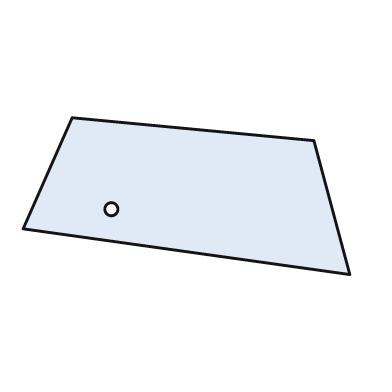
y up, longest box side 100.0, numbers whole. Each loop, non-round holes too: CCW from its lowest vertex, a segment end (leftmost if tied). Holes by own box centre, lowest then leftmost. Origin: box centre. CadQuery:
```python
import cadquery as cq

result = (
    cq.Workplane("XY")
    .moveTo(50.0, -24.0)
    .lineTo(39.0, 17.0)
    .lineTo(-35.0, 24.0)
    .lineTo(-50.0, -10.0)
    .close()
    .moveTo(-23.0, -4.0)
    .circle(2.0)
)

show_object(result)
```